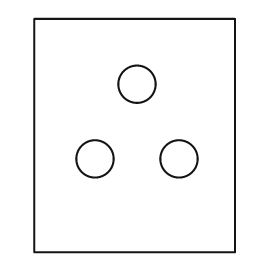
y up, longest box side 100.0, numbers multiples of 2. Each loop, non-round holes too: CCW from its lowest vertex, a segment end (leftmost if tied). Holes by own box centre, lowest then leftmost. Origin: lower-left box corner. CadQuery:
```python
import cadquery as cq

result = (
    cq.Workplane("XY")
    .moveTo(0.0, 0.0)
    .lineTo(86.0, 0.0)
    .lineTo(86.0, 100.0)
    .lineTo(0.0, 100.0)
    .close()
    .moveTo(26.0, 40.0)
    .circle(8.0)
    .moveTo(62.0, 40.0)
    .circle(8.0)
    .moveTo(44.0, 72.0)
    .circle(8.0)
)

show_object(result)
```